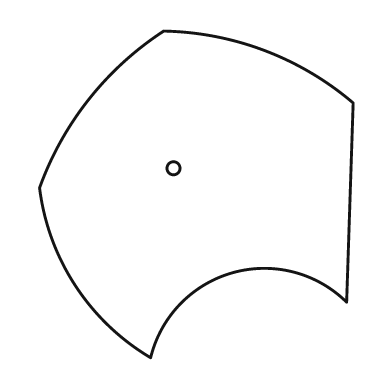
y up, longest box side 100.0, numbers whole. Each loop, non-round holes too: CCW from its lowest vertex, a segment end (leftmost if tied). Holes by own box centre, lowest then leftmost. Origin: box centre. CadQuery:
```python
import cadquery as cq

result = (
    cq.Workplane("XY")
    .moveTo(-14.0, -50.0)
    .threePointArc((11.0, -24.0), (46.0, -33.0))
    .lineTo(48.0, 28.0)
    .threePointArc((21.0, 44.0), (-10.0, 50.0))
    .threePointArc((-33.0, 29.0), (-48.0, 2.0))
    .threePointArc((-37.0, -28.0), (-14.0, -50.0))
    .close()
    .moveTo(-7.0, 8.0)
    .circle(2.0)
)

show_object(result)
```